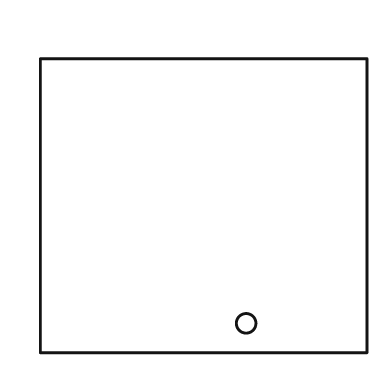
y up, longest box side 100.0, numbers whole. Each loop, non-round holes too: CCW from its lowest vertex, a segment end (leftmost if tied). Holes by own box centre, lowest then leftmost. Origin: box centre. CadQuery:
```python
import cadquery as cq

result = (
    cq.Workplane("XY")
    .moveTo(-50.0, -45.0)
    .lineTo(50.0, -45.0)
    .lineTo(50.0, 45.0)
    .lineTo(-50.0, 45.0)
    .close()
    .moveTo(13.0, -36.0)
    .circle(3.0)
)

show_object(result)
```